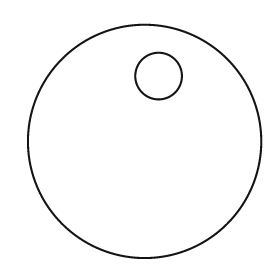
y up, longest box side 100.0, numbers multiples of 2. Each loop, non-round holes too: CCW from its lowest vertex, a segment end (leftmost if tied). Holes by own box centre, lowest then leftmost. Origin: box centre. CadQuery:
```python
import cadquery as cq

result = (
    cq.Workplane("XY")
    .moveTo(0.0, 0.0)
    .circle(50.0)
    .moveTo(6.0, 28.0)
    .circle(10.0)
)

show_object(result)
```